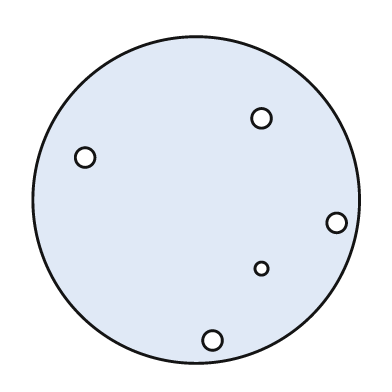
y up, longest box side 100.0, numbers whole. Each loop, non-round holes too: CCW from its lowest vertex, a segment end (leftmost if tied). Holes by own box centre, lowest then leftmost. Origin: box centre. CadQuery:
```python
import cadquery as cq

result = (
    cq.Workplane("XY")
    .moveTo(0.0, 0.0)
    .circle(50.0)
    .moveTo(5.0, -43.0)
    .circle(3.0)
    .moveTo(20.0, -21.0)
    .circle(2.0)
    .moveTo(43.0, -7.0)
    .circle(3.0)
    .moveTo(-34.0, 13.0)
    .circle(3.0)
    .moveTo(20.0, 25.0)
    .circle(3.0)
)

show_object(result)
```